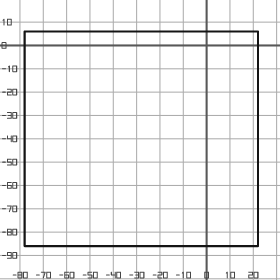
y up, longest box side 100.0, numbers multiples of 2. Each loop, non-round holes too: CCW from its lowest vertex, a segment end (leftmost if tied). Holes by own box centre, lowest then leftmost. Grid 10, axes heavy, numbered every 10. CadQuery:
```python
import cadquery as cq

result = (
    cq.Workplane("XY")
    .moveTo(-78.0, -86.0)
    .lineTo(22.0, -86.0)
    .lineTo(22.0, 6.0)
    .lineTo(-78.0, 6.0)
    .close()
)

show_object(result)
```